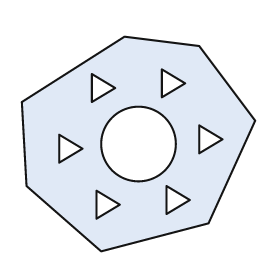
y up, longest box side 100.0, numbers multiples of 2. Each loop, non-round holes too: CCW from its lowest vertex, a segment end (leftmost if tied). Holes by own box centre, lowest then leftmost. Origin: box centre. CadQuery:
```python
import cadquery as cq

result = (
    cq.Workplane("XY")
    .moveTo(-16.0, -46.0)
    .lineTo(30.0, -34.0)
    .lineTo(50.0, 10.0)
    .lineTo(26.0, 42.0)
    .lineTo(-6.0, 46.0)
    .lineTo(-50.0, 18.0)
    .lineTo(-48.0, -18.0)
    .close()
    .moveTo(-18.0, -32.0)
    .lineTo(-8.0, -26.0)
    .lineTo(-18.0, -20.0)
    .close()
    .moveTo(12.0, -30.0)
    .lineTo(22.0, -24.0)
    .lineTo(12.0, -18.0)
    .close()
    .moveTo(-34.0, -8.0)
    .lineTo(-24.0, -2.0)
    .lineTo(-34.0, 4.0)
    .close()
    .moveTo(0.0, 0.0)
    .circle(16.0)
    .moveTo(26.0, -4.0)
    .lineTo(36.0, 2.0)
    .lineTo(26.0, 8.0)
    .close()
    .moveTo(-20.0, 18.0)
    .lineTo(-10.0, 24.0)
    .lineTo(-20.0, 30.0)
    .close()
    .moveTo(10.0, 20.0)
    .lineTo(20.0, 26.0)
    .lineTo(10.0, 32.0)
    .close()
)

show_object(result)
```